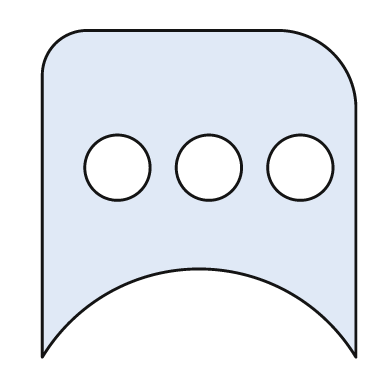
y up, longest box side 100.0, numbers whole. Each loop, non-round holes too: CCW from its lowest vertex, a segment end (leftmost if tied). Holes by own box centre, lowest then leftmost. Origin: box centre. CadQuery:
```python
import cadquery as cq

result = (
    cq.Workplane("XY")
    .moveTo(-48.0, -50.0)
    .threePointArc((0.0, -23.0), (48.0, -50.0))
    .lineTo(48.0, 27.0)
    .threePointArc((41.0, 43.0), (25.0, 50.0))
    .lineTo(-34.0, 50.0)
    .threePointArc((-44.0, 46.0), (-48.0, 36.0))
    .close()
    .moveTo(-25.0, 8.0)
    .circle(10.0)
    .moveTo(3.0, 8.0)
    .circle(10.0)
    .moveTo(31.0, 8.0)
    .circle(10.0)
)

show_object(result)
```